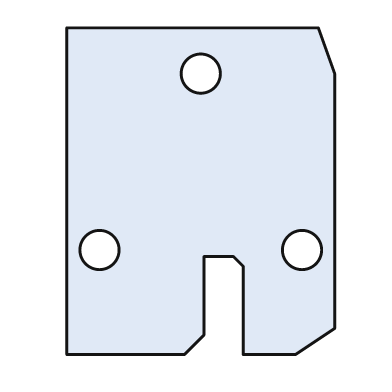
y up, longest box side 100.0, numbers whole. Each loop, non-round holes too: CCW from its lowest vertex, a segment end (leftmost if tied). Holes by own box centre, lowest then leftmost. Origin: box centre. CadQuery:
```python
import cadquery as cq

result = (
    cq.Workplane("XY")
    .moveTo(-41.0, -50.0)
    .lineTo(-5.0, -50.0)
    .lineTo(1.0, -44.0)
    .lineTo(1.0, -20.0)
    .lineTo(10.0, -20.0)
    .lineTo(13.0, -23.0)
    .lineTo(13.0, -50.0)
    .lineTo(29.0, -50.0)
    .lineTo(41.0, -42.0)
    .lineTo(41.0, 36.0)
    .lineTo(36.0, 50.0)
    .lineTo(-41.0, 50.0)
    .close()
    .moveTo(-31.0, -18.0)
    .circle(6.0)
    .moveTo(31.0, -18.0)
    .circle(6.0)
    .moveTo(0.0, 36.0)
    .circle(6.0)
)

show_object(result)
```